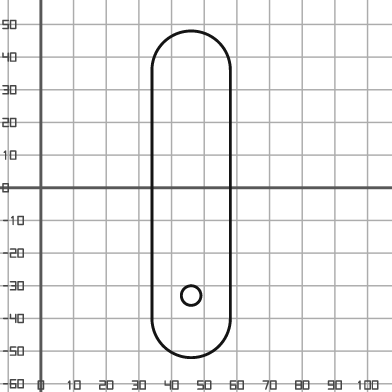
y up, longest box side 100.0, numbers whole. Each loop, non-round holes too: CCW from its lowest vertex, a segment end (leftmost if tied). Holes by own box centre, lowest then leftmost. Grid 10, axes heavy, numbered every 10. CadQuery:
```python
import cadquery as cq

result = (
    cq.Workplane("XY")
    .moveTo(34.0, -40.0)
    .threePointArc((46.0, -52.0), (58.0, -40.0))
    .lineTo(58.0, 36.0)
    .threePointArc((46.0, 48.0), (34.0, 36.0))
    .close()
    .moveTo(46.0, -33.0)
    .circle(3.0)
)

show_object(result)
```